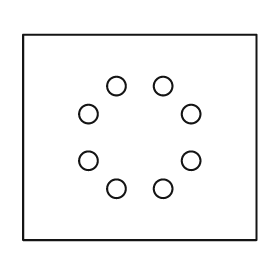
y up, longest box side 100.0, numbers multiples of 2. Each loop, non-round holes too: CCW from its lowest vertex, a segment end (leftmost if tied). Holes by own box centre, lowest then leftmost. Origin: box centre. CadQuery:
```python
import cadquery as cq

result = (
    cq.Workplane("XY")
    .moveTo(-50.0, -44.0)
    .lineTo(50.0, -44.0)
    .lineTo(50.0, 44.0)
    .lineTo(-50.0, 44.0)
    .close()
    .moveTo(-10.0, -22.0)
    .circle(4.0)
    .moveTo(10.0, -22.0)
    .circle(4.0)
    .moveTo(-22.0, -10.0)
    .circle(4.0)
    .moveTo(22.0, -10.0)
    .circle(4.0)
    .moveTo(-22.0, 10.0)
    .circle(4.0)
    .moveTo(22.0, 10.0)
    .circle(4.0)
    .moveTo(-10.0, 22.0)
    .circle(4.0)
    .moveTo(10.0, 22.0)
    .circle(4.0)
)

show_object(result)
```